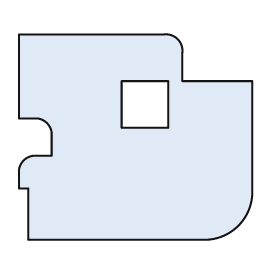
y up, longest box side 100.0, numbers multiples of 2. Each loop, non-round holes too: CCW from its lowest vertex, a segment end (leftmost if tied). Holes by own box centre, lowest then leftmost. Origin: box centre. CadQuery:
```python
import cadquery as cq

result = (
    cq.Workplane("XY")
    .moveTo(-46.0, -44.0)
    .lineTo(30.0, -44.0)
    .threePointArc((44.0, -38.0), (50.0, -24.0))
    .lineTo(50.0, 24.0)
    .lineTo(20.0, 24.0)
    .lineTo(20.0, 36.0)
    .threePointArc((18.0, 42.0), (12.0, 44.0))
    .lineTo(-50.0, 44.0)
    .lineTo(-50.0, 8.0)
    .lineTo(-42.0, 8.0)
    .threePointArc((-38.0, 6.0), (-36.0, 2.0))
    .lineTo(-36.0, -8.0)
    .lineTo(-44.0, -8.0)
    .threePointArc((-48.0, -10.0), (-50.0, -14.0))
    .lineTo(-50.0, -22.0)
    .lineTo(-46.0, -22.0)
    .close()
    .moveTo(-6.0, 4.0)
    .lineTo(14.0, 4.0)
    .lineTo(14.0, 24.0)
    .lineTo(-6.0, 24.0)
    .close()
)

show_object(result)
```